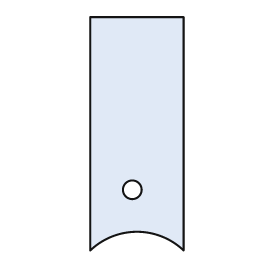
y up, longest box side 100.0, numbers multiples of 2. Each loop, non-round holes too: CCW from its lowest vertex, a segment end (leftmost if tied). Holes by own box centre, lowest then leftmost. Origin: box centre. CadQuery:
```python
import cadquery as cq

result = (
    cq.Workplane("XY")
    .moveTo(-20.0, -50.0)
    .threePointArc((0.0, -42.0), (20.0, -50.0))
    .lineTo(20.0, 50.0)
    .lineTo(-20.0, 50.0)
    .close()
    .moveTo(-2.0, -24.0)
    .circle(4.0)
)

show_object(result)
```